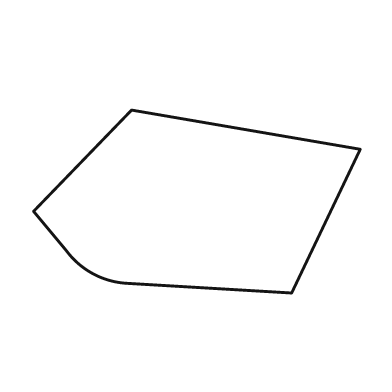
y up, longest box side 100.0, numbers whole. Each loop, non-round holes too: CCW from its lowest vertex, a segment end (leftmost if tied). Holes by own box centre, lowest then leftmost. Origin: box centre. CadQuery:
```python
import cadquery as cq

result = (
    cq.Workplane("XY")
    .moveTo(29.0, -28.0)
    .lineTo(50.0, 16.0)
    .lineTo(-20.0, 28.0)
    .lineTo(-50.0, -3.0)
    .lineTo(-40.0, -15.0)
    .threePointArc((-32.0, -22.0), (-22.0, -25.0))
    .close()
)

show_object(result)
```